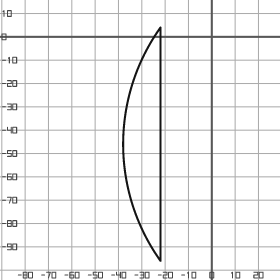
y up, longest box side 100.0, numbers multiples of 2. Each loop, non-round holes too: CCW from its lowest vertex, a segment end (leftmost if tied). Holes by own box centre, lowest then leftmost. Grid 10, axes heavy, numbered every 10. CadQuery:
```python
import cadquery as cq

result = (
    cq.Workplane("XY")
    .moveTo(-22.0, -96.0)
    .lineTo(-22.0, 4.0)
    .threePointArc((-38.0, -46.0), (-22.0, -96.0))
    .close()
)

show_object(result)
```